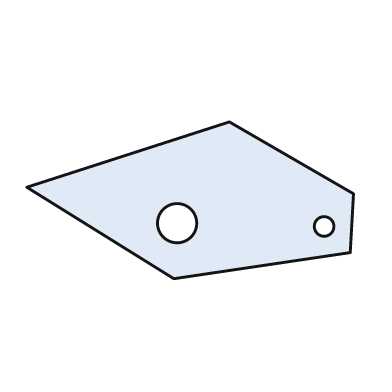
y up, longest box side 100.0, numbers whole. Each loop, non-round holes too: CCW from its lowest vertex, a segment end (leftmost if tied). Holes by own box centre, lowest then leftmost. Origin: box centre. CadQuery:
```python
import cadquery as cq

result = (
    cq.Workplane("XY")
    .moveTo(-5.0, -24.0)
    .lineTo(49.0, -16.0)
    .lineTo(50.0, 2.0)
    .lineTo(12.0, 24.0)
    .lineTo(-50.0, 4.0)
    .close()
    .moveTo(41.0, -8.0)
    .circle(3.0)
    .moveTo(-4.0, -7.0)
    .circle(6.0)
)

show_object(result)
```